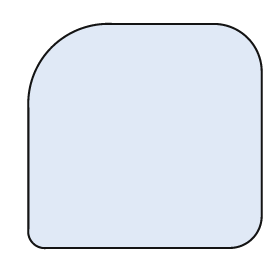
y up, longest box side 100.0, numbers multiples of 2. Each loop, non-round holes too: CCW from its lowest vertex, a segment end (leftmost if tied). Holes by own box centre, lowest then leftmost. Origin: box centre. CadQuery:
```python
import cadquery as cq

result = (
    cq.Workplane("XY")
    .moveTo(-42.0, -48.0)
    .lineTo(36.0, -48.0)
    .threePointArc((46.0, -44.0), (50.0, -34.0))
    .lineTo(50.0, 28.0)
    .threePointArc((44.0, 42.0), (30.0, 48.0))
    .lineTo(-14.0, 48.0)
    .threePointArc((-40.0, 38.0), (-50.0, 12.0))
    .lineTo(-50.0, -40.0)
    .threePointArc((-48.0, -46.0), (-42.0, -48.0))
    .close()
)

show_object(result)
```